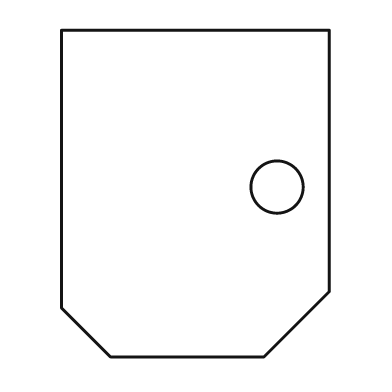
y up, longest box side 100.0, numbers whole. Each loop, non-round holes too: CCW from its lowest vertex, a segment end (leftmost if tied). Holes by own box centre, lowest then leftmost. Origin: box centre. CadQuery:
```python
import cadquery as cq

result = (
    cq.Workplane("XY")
    .moveTo(-26.0, -50.0)
    .lineTo(21.0, -50.0)
    .lineTo(41.0, -30.0)
    .lineTo(41.0, 50.0)
    .lineTo(-41.0, 50.0)
    .lineTo(-41.0, -35.0)
    .close()
    .moveTo(25.0, 2.0)
    .circle(8.0)
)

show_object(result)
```